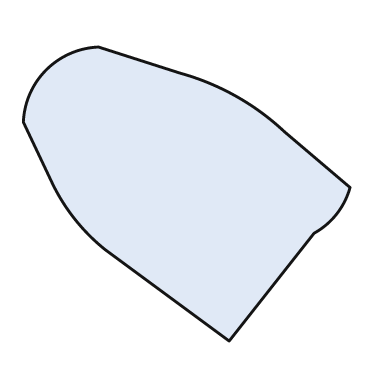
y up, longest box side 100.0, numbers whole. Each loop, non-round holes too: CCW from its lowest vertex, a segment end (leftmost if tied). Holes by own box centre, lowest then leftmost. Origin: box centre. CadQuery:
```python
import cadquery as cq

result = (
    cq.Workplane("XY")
    .moveTo(13.0, -45.0)
    .lineTo(39.0, -12.0)
    .threePointArc((46.0, -6.0), (50.0, 2.0))
    .lineTo(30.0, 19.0)
    .threePointArc((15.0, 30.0), (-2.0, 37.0))
    .lineTo(-27.0, 45.0)
    .threePointArc((-43.0, 38.0), (-50.0, 22.0))
    .lineTo(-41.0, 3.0)
    .threePointArc((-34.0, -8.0), (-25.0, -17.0))
    .close()
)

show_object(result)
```